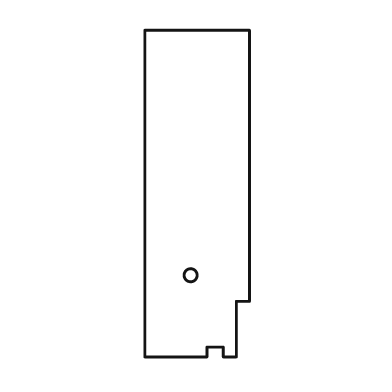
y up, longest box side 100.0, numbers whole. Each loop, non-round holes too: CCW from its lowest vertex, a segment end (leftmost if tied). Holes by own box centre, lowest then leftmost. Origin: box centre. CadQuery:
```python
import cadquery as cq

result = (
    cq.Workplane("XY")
    .moveTo(-16.0, -50.0)
    .lineTo(3.0, -50.0)
    .lineTo(3.0, -47.0)
    .lineTo(8.0, -47.0)
    .lineTo(8.0, -50.0)
    .lineTo(12.0, -50.0)
    .lineTo(12.0, -33.0)
    .lineTo(16.0, -33.0)
    .lineTo(16.0, 50.0)
    .lineTo(-16.0, 50.0)
    .close()
    .moveTo(-2.0, -25.0)
    .circle(2.0)
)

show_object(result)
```